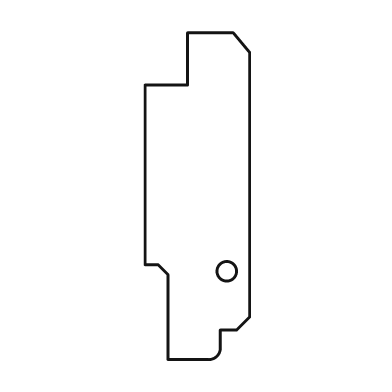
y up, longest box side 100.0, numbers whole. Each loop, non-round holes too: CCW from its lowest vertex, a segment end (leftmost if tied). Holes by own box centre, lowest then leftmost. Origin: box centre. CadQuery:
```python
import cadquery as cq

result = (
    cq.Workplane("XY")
    .moveTo(-9.0, -50.0)
    .lineTo(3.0, -50.0)
    .threePointArc((6.0, -49.0), (7.0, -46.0))
    .lineTo(7.0, -41.0)
    .lineTo(12.0, -41.0)
    .lineTo(16.0, -37.0)
    .lineTo(16.0, 44.0)
    .lineTo(11.0, 50.0)
    .lineTo(-3.0, 50.0)
    .lineTo(-3.0, 34.0)
    .lineTo(-16.0, 34.0)
    .lineTo(-16.0, -21.0)
    .lineTo(-12.0, -21.0)
    .lineTo(-9.0, -24.0)
    .close()
    .moveTo(9.0, -23.0)
    .circle(3.0)
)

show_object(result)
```